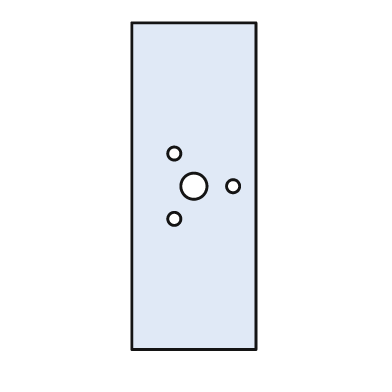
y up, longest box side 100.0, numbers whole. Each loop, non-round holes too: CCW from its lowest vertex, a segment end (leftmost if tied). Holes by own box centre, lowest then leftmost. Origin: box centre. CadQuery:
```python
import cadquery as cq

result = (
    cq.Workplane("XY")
    .moveTo(-19.0, -50.0)
    .lineTo(19.0, -50.0)
    .lineTo(19.0, 50.0)
    .lineTo(-19.0, 50.0)
    .close()
    .moveTo(-6.0, -10.0)
    .circle(2.0)
    .moveTo(0.0, 0.0)
    .circle(4.0)
    .moveTo(12.0, 0.0)
    .circle(2.0)
    .moveTo(-6.0, 10.0)
    .circle(2.0)
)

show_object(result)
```